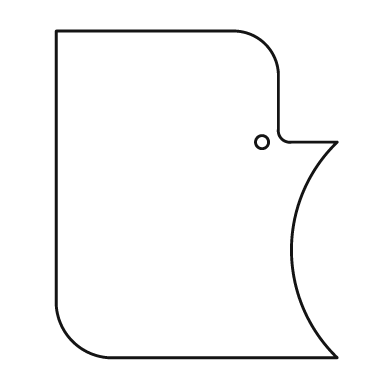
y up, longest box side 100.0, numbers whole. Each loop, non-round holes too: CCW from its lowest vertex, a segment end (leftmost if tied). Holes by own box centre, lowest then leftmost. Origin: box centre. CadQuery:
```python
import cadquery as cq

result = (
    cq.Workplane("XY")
    .moveTo(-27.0, -50.0)
    .lineTo(43.0, -50.0)
    .threePointArc((29.0, -17.0), (43.0, 16.0))
    .lineTo(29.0, 16.0)
    .threePointArc((26.0, 17.0), (25.0, 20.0))
    .lineTo(25.0, 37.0)
    .threePointArc((21.0, 46.0), (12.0, 50.0))
    .lineTo(-43.0, 50.0)
    .lineTo(-43.0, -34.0)
    .threePointArc((-38.0, -45.0), (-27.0, -50.0))
    .close()
    .moveTo(20.0, 16.0)
    .circle(2.0)
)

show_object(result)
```